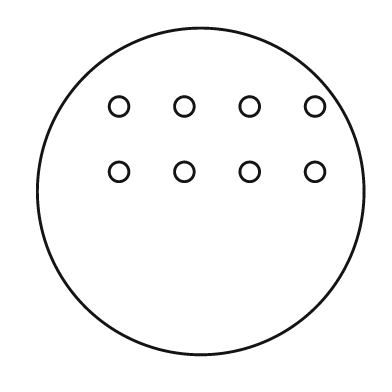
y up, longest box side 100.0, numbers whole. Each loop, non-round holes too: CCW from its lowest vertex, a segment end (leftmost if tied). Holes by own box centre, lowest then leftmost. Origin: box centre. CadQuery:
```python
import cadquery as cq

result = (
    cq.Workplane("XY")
    .moveTo(0.0, 0.0)
    .circle(50.0)
    .moveTo(-25.0, 6.0)
    .circle(3.0)
    .moveTo(-5.0, 6.0)
    .circle(3.0)
    .moveTo(15.0, 6.0)
    .circle(3.0)
    .moveTo(35.0, 6.0)
    .circle(3.0)
    .moveTo(-25.0, 26.0)
    .circle(3.0)
    .moveTo(-5.0, 26.0)
    .circle(3.0)
    .moveTo(15.0, 26.0)
    .circle(3.0)
    .moveTo(35.0, 26.0)
    .circle(3.0)
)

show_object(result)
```